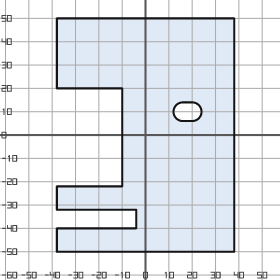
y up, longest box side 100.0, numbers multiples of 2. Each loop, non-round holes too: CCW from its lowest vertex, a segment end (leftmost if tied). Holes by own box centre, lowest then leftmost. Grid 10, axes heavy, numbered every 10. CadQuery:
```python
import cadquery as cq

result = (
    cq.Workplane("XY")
    .moveTo(-38.0, -50.0)
    .lineTo(38.0, -50.0)
    .lineTo(38.0, 50.0)
    .lineTo(-38.0, 50.0)
    .lineTo(-38.0, 20.0)
    .lineTo(-10.0, 20.0)
    .lineTo(-10.0, -22.0)
    .lineTo(-38.0, -22.0)
    .lineTo(-38.0, -32.0)
    .lineTo(-4.0, -32.0)
    .lineTo(-4.0, -40.0)
    .lineTo(-38.0, -40.0)
    .close()
    .moveTo(16.0, 6.0)
    .lineTo(20.0, 6.0)
    .threePointArc((24.0, 10.0), (20.0, 14.0))
    .lineTo(16.0, 14.0)
    .threePointArc((12.0, 10.0), (16.0, 6.0))
    .close()
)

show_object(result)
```